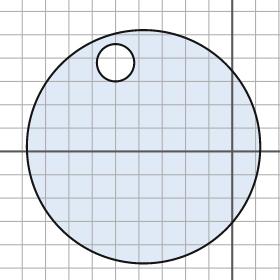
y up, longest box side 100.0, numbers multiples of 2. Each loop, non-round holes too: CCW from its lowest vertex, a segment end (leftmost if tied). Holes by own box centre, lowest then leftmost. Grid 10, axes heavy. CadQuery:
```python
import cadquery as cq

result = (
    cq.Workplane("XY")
    .moveTo(-38.0, 2.0)
    .circle(50.0)
    .moveTo(-50.0, 38.0)
    .circle(8.0)
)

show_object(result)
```